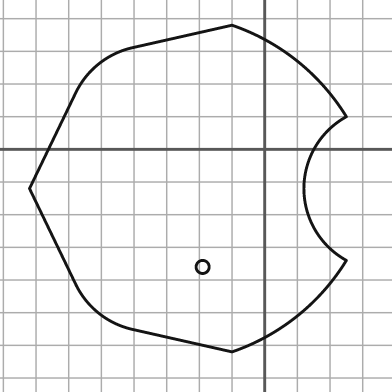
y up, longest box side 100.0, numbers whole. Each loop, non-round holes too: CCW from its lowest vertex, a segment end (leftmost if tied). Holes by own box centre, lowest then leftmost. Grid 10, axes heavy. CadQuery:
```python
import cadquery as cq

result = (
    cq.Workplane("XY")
    .moveTo(-10.0, -62.0)
    .threePointArc((10.0, -51.0), (25.0, -34.0))
    .threePointArc((12.0, -12.0), (25.0, 10.0))
    .threePointArc((10.0, 27.0), (-10.0, 38.0))
    .lineTo(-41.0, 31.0)
    .threePointArc((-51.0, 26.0), (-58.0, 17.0))
    .lineTo(-72.0, -12.0)
    .lineTo(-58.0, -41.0)
    .threePointArc((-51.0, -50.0), (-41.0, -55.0))
    .close()
    .moveTo(-19.0, -36.0)
    .circle(2.0)
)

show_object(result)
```